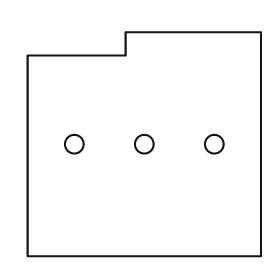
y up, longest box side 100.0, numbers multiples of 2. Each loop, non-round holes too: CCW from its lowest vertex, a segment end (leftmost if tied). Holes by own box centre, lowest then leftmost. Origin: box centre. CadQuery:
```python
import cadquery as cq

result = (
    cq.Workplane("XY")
    .moveTo(-50.0, -48.0)
    .lineTo(50.0, -48.0)
    .lineTo(50.0, 48.0)
    .lineTo(-8.0, 48.0)
    .lineTo(-8.0, 38.0)
    .lineTo(-50.0, 38.0)
    .close()
    .moveTo(-30.0, 0.0)
    .circle(4.0)
    .moveTo(0.0, 0.0)
    .circle(4.0)
    .moveTo(30.0, 0.0)
    .circle(4.0)
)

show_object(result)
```